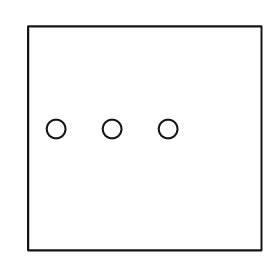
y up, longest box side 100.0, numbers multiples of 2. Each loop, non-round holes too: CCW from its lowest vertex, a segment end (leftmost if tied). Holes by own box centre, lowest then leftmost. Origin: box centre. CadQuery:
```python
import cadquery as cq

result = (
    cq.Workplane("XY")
    .moveTo(-50.0, -48.0)
    .lineTo(50.0, -48.0)
    .lineTo(50.0, 48.0)
    .lineTo(-50.0, 48.0)
    .close()
    .moveTo(-38.0, 4.0)
    .circle(4.0)
    .moveTo(-14.0, 4.0)
    .circle(4.0)
    .moveTo(10.0, 4.0)
    .circle(4.0)
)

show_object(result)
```